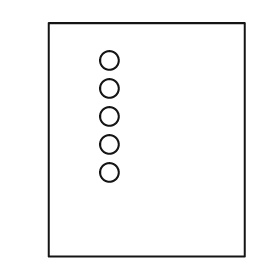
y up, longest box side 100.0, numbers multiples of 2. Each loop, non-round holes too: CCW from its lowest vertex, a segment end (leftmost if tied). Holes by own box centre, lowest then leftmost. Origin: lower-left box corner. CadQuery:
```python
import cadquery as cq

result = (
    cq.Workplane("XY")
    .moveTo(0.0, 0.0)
    .lineTo(84.0, 0.0)
    .lineTo(84.0, 100.0)
    .lineTo(0.0, 100.0)
    .close()
    .moveTo(26.0, 36.0)
    .circle(4.0)
    .moveTo(26.0, 48.0)
    .circle(4.0)
    .moveTo(26.0, 60.0)
    .circle(4.0)
    .moveTo(26.0, 72.0)
    .circle(4.0)
    .moveTo(26.0, 84.0)
    .circle(4.0)
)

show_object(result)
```